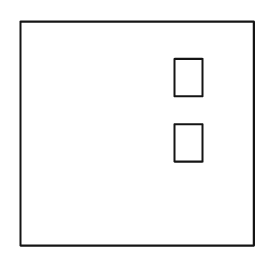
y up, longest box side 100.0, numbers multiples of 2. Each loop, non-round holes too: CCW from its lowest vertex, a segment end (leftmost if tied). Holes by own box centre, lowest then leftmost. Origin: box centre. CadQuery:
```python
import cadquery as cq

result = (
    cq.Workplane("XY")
    .moveTo(-50.0, -48.0)
    .lineTo(50.0, -48.0)
    .lineTo(50.0, 48.0)
    .lineTo(-50.0, 48.0)
    .close()
    .moveTo(16.0, -12.0)
    .lineTo(28.0, -12.0)
    .lineTo(28.0, 4.0)
    .lineTo(16.0, 4.0)
    .close()
    .moveTo(16.0, 16.0)
    .lineTo(28.0, 16.0)
    .lineTo(28.0, 32.0)
    .lineTo(16.0, 32.0)
    .close()
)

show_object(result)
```